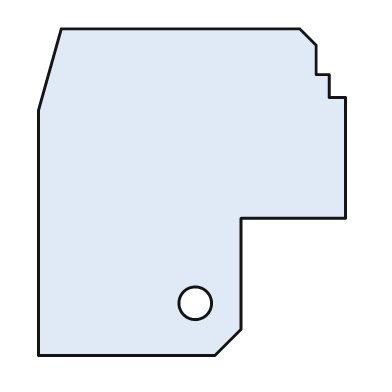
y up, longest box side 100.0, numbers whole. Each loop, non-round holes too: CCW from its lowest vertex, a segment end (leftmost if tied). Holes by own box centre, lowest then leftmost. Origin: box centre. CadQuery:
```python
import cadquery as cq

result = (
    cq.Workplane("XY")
    .moveTo(-47.0, -50.0)
    .lineTo(7.0, -50.0)
    .lineTo(15.0, -42.0)
    .lineTo(15.0, -8.0)
    .lineTo(47.0, -8.0)
    .lineTo(47.0, 29.0)
    .lineTo(42.0, 29.0)
    .lineTo(42.0, 36.0)
    .lineTo(38.0, 36.0)
    .lineTo(38.0, 45.0)
    .lineTo(33.0, 50.0)
    .lineTo(-40.0, 50.0)
    .lineTo(-47.0, 25.0)
    .close()
    .moveTo(1.0, -34.0)
    .circle(5.0)
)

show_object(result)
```